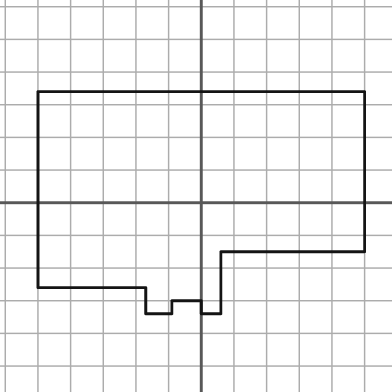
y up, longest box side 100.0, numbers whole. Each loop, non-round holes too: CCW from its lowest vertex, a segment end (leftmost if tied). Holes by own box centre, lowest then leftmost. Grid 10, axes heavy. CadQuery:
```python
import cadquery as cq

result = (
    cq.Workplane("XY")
    .moveTo(-17.0, -34.0)
    .lineTo(-9.0, -34.0)
    .lineTo(-9.0, -30.0)
    .lineTo(0.0, -30.0)
    .lineTo(0.0, -34.0)
    .lineTo(6.0, -34.0)
    .lineTo(6.0, -15.0)
    .lineTo(50.0, -15.0)
    .lineTo(50.0, 34.0)
    .lineTo(-50.0, 34.0)
    .lineTo(-50.0, -26.0)
    .lineTo(-17.0, -26.0)
    .close()
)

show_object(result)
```